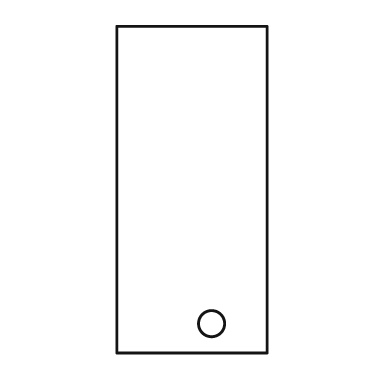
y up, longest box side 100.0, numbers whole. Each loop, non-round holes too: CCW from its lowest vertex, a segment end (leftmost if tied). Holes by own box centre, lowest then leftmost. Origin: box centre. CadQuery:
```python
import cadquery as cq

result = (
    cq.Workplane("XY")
    .moveTo(-23.0, -50.0)
    .lineTo(23.0, -50.0)
    .lineTo(23.0, 50.0)
    .lineTo(-23.0, 50.0)
    .close()
    .moveTo(6.0, -41.0)
    .circle(4.0)
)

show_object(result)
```